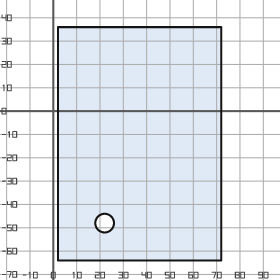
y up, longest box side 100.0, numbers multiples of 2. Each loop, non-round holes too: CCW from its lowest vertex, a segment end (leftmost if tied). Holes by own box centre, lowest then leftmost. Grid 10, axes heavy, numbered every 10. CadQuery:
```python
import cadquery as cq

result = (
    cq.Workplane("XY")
    .moveTo(2.0, -64.0)
    .lineTo(72.0, -64.0)
    .lineTo(72.0, 36.0)
    .lineTo(2.0, 36.0)
    .close()
    .moveTo(22.0, -48.0)
    .circle(4.0)
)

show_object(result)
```